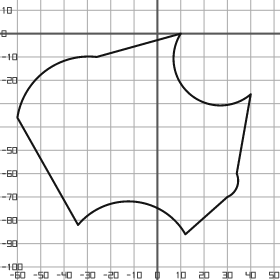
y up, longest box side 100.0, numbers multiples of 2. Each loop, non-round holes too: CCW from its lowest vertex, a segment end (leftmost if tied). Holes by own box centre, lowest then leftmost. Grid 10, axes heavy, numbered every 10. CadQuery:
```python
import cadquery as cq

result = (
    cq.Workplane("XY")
    .moveTo(12.0, -86.0)
    .lineTo(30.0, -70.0)
    .threePointArc((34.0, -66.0), (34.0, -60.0))
    .lineTo(40.0, -26.0)
    .threePointArc((14.0, -26.0), (10.0, 0.0))
    .lineTo(-26.0, -10.0)
    .threePointArc((-48.0, -16.0), (-60.0, -36.0))
    .lineTo(-34.0, -82.0)
    .threePointArc((-10.0, -72.0), (12.0, -86.0))
    .close()
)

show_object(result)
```